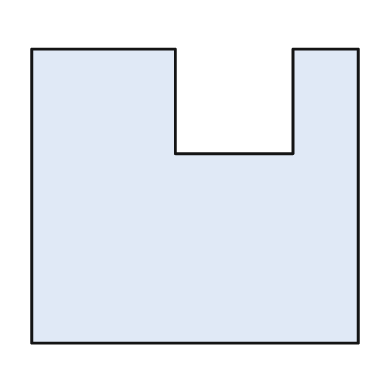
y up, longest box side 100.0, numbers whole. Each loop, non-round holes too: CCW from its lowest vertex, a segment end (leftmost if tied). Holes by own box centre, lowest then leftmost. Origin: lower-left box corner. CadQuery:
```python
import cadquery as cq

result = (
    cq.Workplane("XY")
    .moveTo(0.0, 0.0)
    .lineTo(100.0, 0.0)
    .lineTo(100.0, 90.0)
    .lineTo(80.0, 90.0)
    .lineTo(80.0, 58.0)
    .lineTo(44.0, 58.0)
    .lineTo(44.0, 90.0)
    .lineTo(0.0, 90.0)
    .close()
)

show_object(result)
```